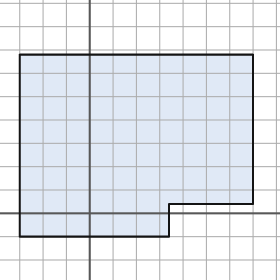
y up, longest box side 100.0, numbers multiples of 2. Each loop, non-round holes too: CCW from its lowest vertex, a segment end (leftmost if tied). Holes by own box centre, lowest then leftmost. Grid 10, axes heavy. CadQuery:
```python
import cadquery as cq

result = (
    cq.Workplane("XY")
    .moveTo(-30.0, -10.0)
    .lineTo(34.0, -10.0)
    .lineTo(34.0, 4.0)
    .lineTo(70.0, 4.0)
    .lineTo(70.0, 68.0)
    .lineTo(-30.0, 68.0)
    .close()
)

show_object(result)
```